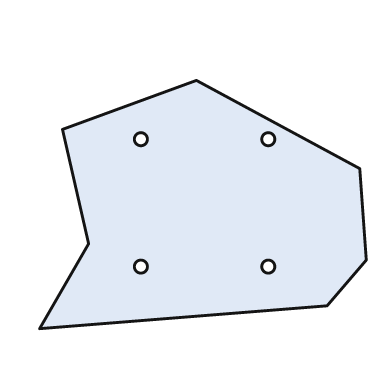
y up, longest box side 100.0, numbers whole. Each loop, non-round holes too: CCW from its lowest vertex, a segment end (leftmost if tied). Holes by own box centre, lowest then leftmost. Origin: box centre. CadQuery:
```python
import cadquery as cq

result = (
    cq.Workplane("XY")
    .moveTo(-50.0, -38.0)
    .lineTo(38.0, -31.0)
    .lineTo(50.0, -17.0)
    .lineTo(48.0, 11.0)
    .lineTo(-2.0, 38.0)
    .lineTo(-43.0, 23.0)
    .lineTo(-35.0, -12.0)
    .close()
    .moveTo(-19.0, -19.0)
    .circle(2.0)
    .moveTo(20.0, -19.0)
    .circle(2.0)
    .moveTo(-19.0, 20.0)
    .circle(2.0)
    .moveTo(20.0, 20.0)
    .circle(2.0)
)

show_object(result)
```